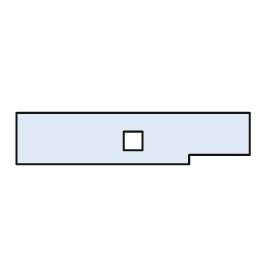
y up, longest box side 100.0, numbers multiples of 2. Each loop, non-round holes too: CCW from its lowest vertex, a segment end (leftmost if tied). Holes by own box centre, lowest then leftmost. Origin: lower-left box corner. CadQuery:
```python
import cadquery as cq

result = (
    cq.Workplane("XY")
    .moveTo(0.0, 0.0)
    .lineTo(74.0, 0.0)
    .lineTo(74.0, 4.0)
    .lineTo(100.0, 4.0)
    .lineTo(100.0, 22.0)
    .lineTo(0.0, 22.0)
    .close()
    .moveTo(46.0, 6.0)
    .lineTo(54.0, 6.0)
    .lineTo(54.0, 14.0)
    .lineTo(46.0, 14.0)
    .close()
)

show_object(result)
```